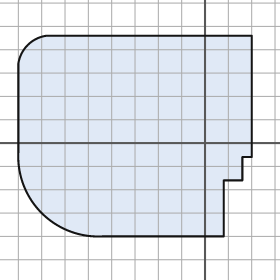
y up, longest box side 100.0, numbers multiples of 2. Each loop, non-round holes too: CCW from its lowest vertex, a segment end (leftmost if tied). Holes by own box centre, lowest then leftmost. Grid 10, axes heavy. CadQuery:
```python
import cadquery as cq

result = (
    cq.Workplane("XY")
    .moveTo(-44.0, -40.0)
    .lineTo(8.0, -40.0)
    .lineTo(8.0, -16.0)
    .lineTo(16.0, -16.0)
    .lineTo(16.0, -6.0)
    .lineTo(20.0, -6.0)
    .lineTo(20.0, 46.0)
    .lineTo(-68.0, 46.0)
    .threePointArc((-76.0, 42.0), (-80.0, 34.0))
    .lineTo(-80.0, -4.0)
    .threePointArc((-70.0, -30.0), (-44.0, -40.0))
    .close()
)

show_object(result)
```